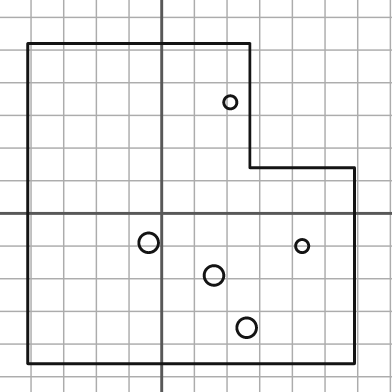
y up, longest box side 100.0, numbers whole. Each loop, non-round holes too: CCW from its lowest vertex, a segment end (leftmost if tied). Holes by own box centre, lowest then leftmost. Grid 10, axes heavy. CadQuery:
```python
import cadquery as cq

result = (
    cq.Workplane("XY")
    .moveTo(-41.0, -46.0)
    .lineTo(59.0, -46.0)
    .lineTo(59.0, 14.0)
    .lineTo(27.0, 14.0)
    .lineTo(27.0, 52.0)
    .lineTo(-41.0, 52.0)
    .close()
    .moveTo(26.0, -35.0)
    .circle(3.0)
    .moveTo(16.0, -19.0)
    .circle(3.0)
    .moveTo(43.0, -10.0)
    .circle(2.0)
    .moveTo(-4.0, -9.0)
    .circle(3.0)
    .moveTo(21.0, 34.0)
    .circle(2.0)
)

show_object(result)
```